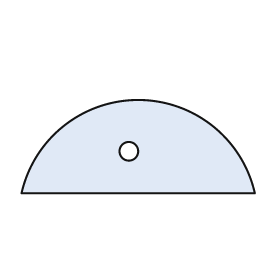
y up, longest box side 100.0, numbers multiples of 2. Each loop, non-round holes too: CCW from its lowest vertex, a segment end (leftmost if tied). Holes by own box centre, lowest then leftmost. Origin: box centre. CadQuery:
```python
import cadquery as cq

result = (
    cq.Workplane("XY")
    .moveTo(-50.0, -20.0)
    .lineTo(50.0, -20.0)
    .threePointArc((0.0, 20.0), (-50.0, -20.0))
    .close()
    .moveTo(-4.0, -2.0)
    .circle(4.0)
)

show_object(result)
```